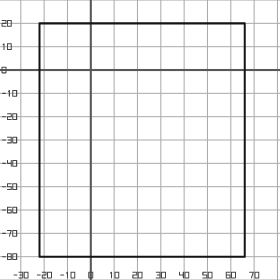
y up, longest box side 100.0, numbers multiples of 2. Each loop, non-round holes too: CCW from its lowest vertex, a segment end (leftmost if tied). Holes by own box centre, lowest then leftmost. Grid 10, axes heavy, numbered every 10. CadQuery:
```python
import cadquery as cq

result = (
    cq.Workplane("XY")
    .moveTo(-22.0, -80.0)
    .lineTo(66.0, -80.0)
    .lineTo(66.0, 20.0)
    .lineTo(-22.0, 20.0)
    .close()
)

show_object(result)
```